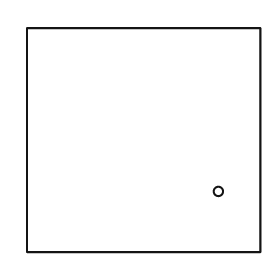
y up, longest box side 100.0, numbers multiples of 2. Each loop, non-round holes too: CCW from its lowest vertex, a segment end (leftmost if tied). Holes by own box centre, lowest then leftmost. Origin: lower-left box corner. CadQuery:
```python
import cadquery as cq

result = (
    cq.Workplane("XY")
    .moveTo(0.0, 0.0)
    .lineTo(100.0, 0.0)
    .lineTo(100.0, 96.0)
    .lineTo(0.0, 96.0)
    .close()
    .moveTo(82.0, 26.0)
    .circle(2.0)
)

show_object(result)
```